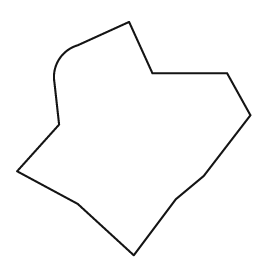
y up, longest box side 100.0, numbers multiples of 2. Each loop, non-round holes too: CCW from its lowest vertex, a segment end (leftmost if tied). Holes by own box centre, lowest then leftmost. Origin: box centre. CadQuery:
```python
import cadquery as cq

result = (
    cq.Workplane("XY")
    .moveTo(0.0, -50.0)
    .lineTo(18.0, -26.0)
    .lineTo(30.0, -16.0)
    .lineTo(50.0, 10.0)
    .lineTo(40.0, 28.0)
    .lineTo(8.0, 28.0)
    .lineTo(-2.0, 50.0)
    .lineTo(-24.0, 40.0)
    .threePointArc((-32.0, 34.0), (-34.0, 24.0))
    .lineTo(-32.0, 6.0)
    .lineTo(-50.0, -14.0)
    .lineTo(-24.0, -28.0)
    .close()
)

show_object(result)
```